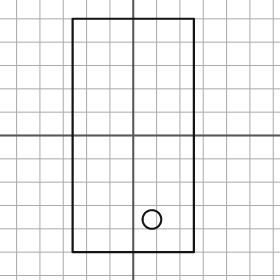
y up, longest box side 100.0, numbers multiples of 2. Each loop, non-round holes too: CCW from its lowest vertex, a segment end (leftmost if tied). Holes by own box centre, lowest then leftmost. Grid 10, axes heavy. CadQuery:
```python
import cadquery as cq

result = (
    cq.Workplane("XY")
    .moveTo(-26.0, -50.0)
    .lineTo(26.0, -50.0)
    .lineTo(26.0, 50.0)
    .lineTo(-26.0, 50.0)
    .close()
    .moveTo(8.0, -36.0)
    .circle(4.0)
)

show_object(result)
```